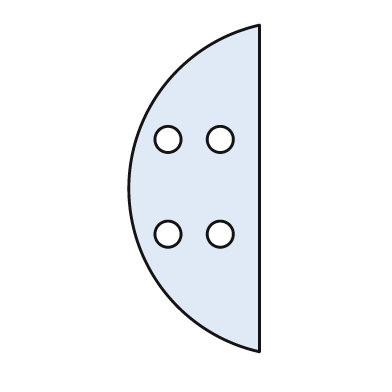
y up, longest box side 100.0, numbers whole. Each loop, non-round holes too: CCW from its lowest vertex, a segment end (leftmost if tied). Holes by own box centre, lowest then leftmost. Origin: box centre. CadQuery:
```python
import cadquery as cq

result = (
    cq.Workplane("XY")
    .moveTo(20.0, -50.0)
    .lineTo(20.0, 50.0)
    .threePointArc((-20.0, 0.0), (20.0, -50.0))
    .close()
    .moveTo(-8.0, -14.0)
    .circle(4.0)
    .moveTo(8.0, -14.0)
    .circle(4.0)
    .moveTo(-8.0, 15.0)
    .circle(4.0)
    .moveTo(8.0, 15.0)
    .circle(4.0)
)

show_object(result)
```